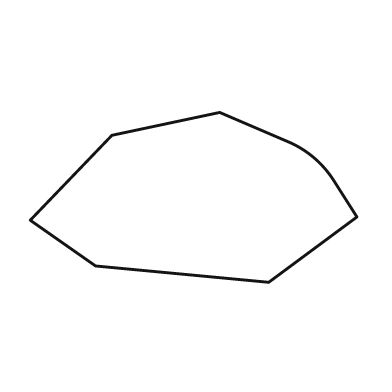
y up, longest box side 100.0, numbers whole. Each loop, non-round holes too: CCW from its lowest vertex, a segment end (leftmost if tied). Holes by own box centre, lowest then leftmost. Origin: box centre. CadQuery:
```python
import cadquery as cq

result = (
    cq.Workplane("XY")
    .moveTo(23.0, -26.0)
    .lineTo(50.0, -6.0)
    .lineTo(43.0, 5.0)
    .threePointArc((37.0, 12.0), (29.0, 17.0))
    .lineTo(8.0, 26.0)
    .lineTo(-25.0, 19.0)
    .lineTo(-50.0, -7.0)
    .lineTo(-30.0, -21.0)
    .close()
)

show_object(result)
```